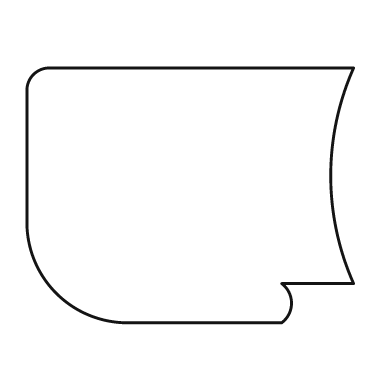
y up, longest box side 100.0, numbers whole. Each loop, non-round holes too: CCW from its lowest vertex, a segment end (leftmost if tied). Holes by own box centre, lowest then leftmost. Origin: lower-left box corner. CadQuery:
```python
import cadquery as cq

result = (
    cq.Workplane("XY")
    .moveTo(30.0, 0.0)
    .lineTo(78.0, 0.0)
    .threePointArc((81.0, 6.0), (78.0, 12.0))
    .lineTo(100.0, 12.0)
    .threePointArc((93.0, 45.0), (100.0, 78.0))
    .lineTo(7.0, 78.0)
    .threePointArc((2.0, 76.0), (0.0, 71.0))
    .lineTo(0.0, 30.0)
    .threePointArc((9.0, 9.0), (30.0, 0.0))
    .close()
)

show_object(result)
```